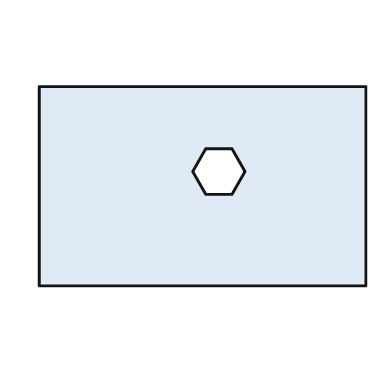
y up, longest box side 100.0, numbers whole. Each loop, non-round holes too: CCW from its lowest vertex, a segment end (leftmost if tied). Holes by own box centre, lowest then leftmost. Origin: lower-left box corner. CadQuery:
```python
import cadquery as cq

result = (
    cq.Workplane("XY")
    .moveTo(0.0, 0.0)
    .lineTo(100.0, 0.0)
    .lineTo(100.0, 61.0)
    .lineTo(0.0, 61.0)
    .close()
    .moveTo(51.0, 28.0)
    .lineTo(59.0, 28.0)
    .lineTo(63.0, 35.0)
    .lineTo(59.0, 42.0)
    .lineTo(51.0, 42.0)
    .lineTo(47.0, 35.0)
    .close()
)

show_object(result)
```